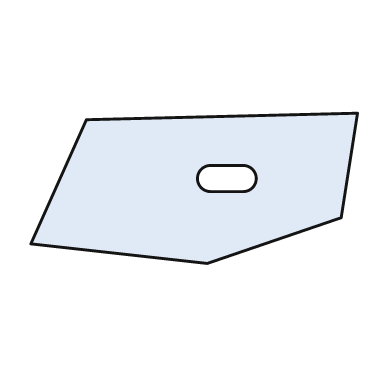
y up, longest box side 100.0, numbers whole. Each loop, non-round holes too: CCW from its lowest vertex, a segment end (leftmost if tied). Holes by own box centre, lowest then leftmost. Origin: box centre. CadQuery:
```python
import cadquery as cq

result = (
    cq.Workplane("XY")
    .moveTo(4.0, -23.0)
    .lineTo(45.0, -9.0)
    .lineTo(50.0, 23.0)
    .lineTo(-33.0, 21.0)
    .lineTo(-50.0, -17.0)
    .close()
    .moveTo(5.0, -1.0)
    .lineTo(15.0, -1.0)
    .threePointArc((19.0, 3.0), (15.0, 7.0))
    .lineTo(5.0, 7.0)
    .threePointArc((1.0, 3.0), (5.0, -1.0))
    .close()
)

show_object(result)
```